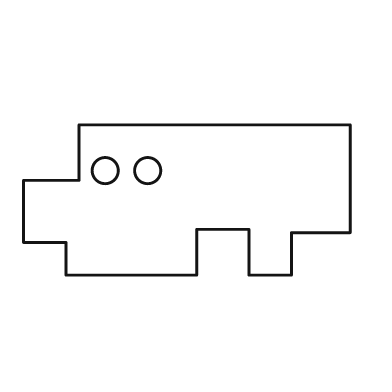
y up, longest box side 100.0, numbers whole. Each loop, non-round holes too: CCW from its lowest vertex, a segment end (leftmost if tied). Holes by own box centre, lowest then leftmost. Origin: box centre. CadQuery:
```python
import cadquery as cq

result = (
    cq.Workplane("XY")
    .moveTo(-37.0, -23.0)
    .lineTo(3.0, -23.0)
    .lineTo(3.0, -9.0)
    .lineTo(19.0, -9.0)
    .lineTo(19.0, -23.0)
    .lineTo(32.0, -23.0)
    .lineTo(32.0, -10.0)
    .lineTo(50.0, -10.0)
    .lineTo(50.0, 23.0)
    .lineTo(-33.0, 23.0)
    .lineTo(-33.0, 6.0)
    .lineTo(-50.0, 6.0)
    .lineTo(-50.0, -13.0)
    .lineTo(-37.0, -13.0)
    .close()
    .moveTo(-25.0, 9.0)
    .circle(4.0)
    .moveTo(-12.0, 9.0)
    .circle(4.0)
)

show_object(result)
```